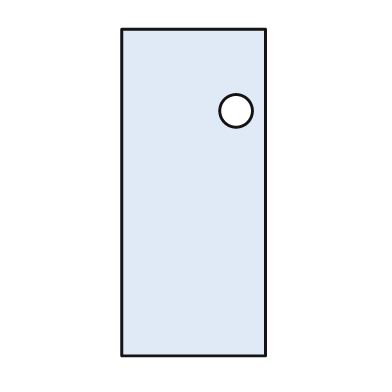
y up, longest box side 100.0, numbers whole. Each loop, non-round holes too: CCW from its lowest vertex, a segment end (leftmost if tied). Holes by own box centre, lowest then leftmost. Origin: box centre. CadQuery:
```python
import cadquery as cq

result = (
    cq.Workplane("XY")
    .moveTo(-22.0, -50.0)
    .lineTo(22.0, -50.0)
    .lineTo(22.0, 50.0)
    .lineTo(-22.0, 50.0)
    .close()
    .moveTo(13.0, 25.0)
    .circle(5.0)
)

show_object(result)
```